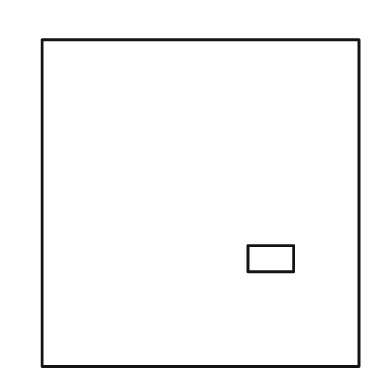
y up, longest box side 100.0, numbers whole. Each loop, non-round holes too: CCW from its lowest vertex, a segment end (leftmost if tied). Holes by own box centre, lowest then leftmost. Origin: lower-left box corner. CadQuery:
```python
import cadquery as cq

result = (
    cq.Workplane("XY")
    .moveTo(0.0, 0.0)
    .lineTo(97.0, 0.0)
    .lineTo(97.0, 100.0)
    .lineTo(0.0, 100.0)
    .close()
    .moveTo(63.0, 29.0)
    .lineTo(77.0, 29.0)
    .lineTo(77.0, 37.0)
    .lineTo(63.0, 37.0)
    .close()
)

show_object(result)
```